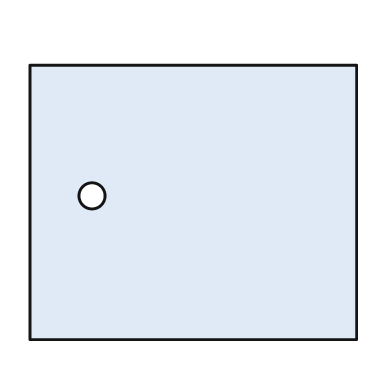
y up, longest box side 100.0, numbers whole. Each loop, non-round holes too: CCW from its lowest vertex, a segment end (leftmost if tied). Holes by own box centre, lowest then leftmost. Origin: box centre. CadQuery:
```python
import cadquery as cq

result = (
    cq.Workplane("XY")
    .moveTo(-50.0, -42.0)
    .lineTo(50.0, -42.0)
    .lineTo(50.0, 42.0)
    .lineTo(-50.0, 42.0)
    .close()
    .moveTo(-31.0, 2.0)
    .circle(4.0)
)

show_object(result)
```